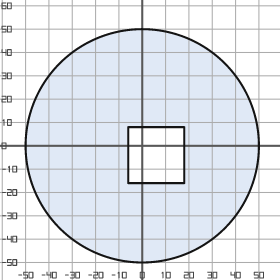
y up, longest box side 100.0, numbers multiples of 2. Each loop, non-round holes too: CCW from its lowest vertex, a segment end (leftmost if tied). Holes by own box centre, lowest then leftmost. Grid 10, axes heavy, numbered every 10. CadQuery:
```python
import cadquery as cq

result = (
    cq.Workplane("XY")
    .moveTo(0.0, 0.0)
    .circle(50.0)
    .moveTo(-6.0, -16.0)
    .lineTo(18.0, -16.0)
    .lineTo(18.0, 8.0)
    .lineTo(-6.0, 8.0)
    .close()
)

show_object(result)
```